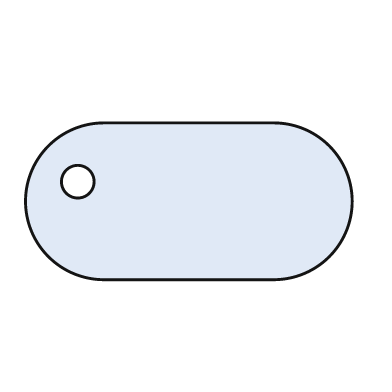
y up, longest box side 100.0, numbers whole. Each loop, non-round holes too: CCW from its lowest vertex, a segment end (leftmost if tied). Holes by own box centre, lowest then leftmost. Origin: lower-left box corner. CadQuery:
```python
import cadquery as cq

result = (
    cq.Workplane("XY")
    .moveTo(24.0, 0.0)
    .lineTo(76.0, 0.0)
    .threePointArc((100.0, 24.0), (76.0, 48.0))
    .lineTo(24.0, 48.0)
    .threePointArc((0.0, 24.0), (24.0, 0.0))
    .close()
    .moveTo(16.0, 30.0)
    .circle(5.0)
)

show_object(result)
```